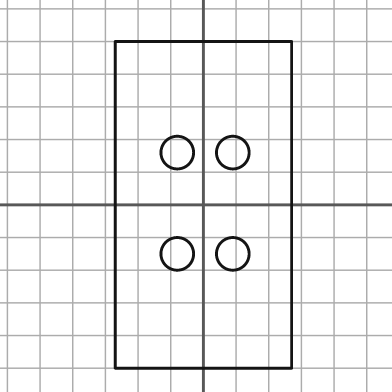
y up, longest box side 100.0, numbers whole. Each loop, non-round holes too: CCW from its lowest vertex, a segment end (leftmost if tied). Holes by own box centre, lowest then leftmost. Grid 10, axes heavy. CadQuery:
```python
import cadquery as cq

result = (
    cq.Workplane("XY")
    .moveTo(-27.0, -50.0)
    .lineTo(27.0, -50.0)
    .lineTo(27.0, 50.0)
    .lineTo(-27.0, 50.0)
    .close()
    .moveTo(-8.0, -15.0)
    .circle(5.0)
    .moveTo(9.0, -15.0)
    .circle(5.0)
    .moveTo(-8.0, 16.0)
    .circle(5.0)
    .moveTo(9.0, 16.0)
    .circle(5.0)
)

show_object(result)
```